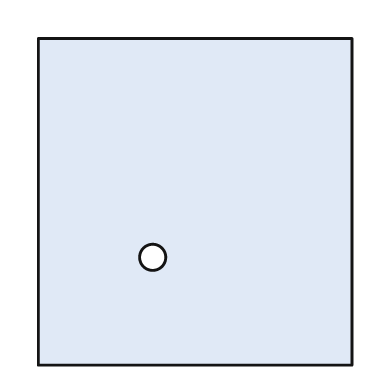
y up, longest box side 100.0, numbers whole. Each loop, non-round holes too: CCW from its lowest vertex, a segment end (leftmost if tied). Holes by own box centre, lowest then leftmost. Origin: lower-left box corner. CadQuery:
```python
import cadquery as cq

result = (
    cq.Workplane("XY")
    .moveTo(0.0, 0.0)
    .lineTo(96.0, 0.0)
    .lineTo(96.0, 100.0)
    .lineTo(0.0, 100.0)
    .close()
    .moveTo(35.0, 33.0)
    .circle(4.0)
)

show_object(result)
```